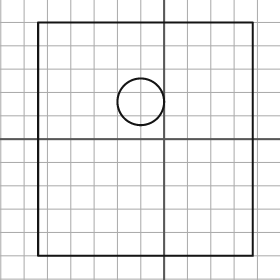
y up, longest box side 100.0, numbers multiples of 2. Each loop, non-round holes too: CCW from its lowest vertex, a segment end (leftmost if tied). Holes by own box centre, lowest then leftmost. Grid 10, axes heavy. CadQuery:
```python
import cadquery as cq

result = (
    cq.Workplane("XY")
    .moveTo(-54.0, -50.0)
    .lineTo(38.0, -50.0)
    .lineTo(38.0, 50.0)
    .lineTo(-54.0, 50.0)
    .close()
    .moveTo(-10.0, 16.0)
    .circle(10.0)
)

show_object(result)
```